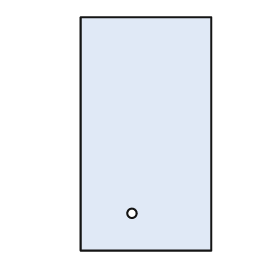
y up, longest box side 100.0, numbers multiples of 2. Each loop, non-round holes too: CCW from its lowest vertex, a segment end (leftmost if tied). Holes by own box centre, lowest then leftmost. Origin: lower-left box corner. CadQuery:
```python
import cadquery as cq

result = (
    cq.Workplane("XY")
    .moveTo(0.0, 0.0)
    .lineTo(56.0, 0.0)
    .lineTo(56.0, 100.0)
    .lineTo(0.0, 100.0)
    .close()
    .moveTo(22.0, 16.0)
    .circle(2.0)
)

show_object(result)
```